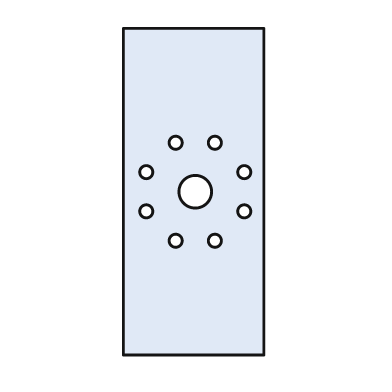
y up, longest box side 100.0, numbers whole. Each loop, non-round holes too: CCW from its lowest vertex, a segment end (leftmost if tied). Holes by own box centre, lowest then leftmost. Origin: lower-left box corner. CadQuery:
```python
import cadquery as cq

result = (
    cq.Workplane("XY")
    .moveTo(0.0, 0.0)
    .lineTo(43.0, 0.0)
    .lineTo(43.0, 100.0)
    .lineTo(0.0, 100.0)
    .close()
    .moveTo(16.0, 35.0)
    .circle(2.0)
    .moveTo(28.0, 35.0)
    .circle(2.0)
    .moveTo(7.0, 44.0)
    .circle(2.0)
    .moveTo(37.0, 44.0)
    .circle(2.0)
    .moveTo(22.0, 50.0)
    .circle(5.0)
    .moveTo(7.0, 56.0)
    .circle(2.0)
    .moveTo(37.0, 56.0)
    .circle(2.0)
    .moveTo(16.0, 65.0)
    .circle(2.0)
    .moveTo(28.0, 65.0)
    .circle(2.0)
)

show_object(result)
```